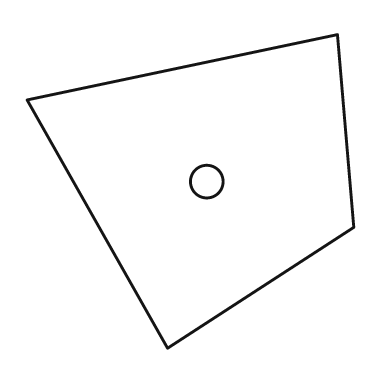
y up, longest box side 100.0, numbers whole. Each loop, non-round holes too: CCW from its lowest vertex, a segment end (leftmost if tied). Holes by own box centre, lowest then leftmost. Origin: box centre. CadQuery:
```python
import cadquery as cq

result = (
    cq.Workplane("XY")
    .moveTo(-7.0, -48.0)
    .lineTo(50.0, -11.0)
    .lineTo(45.0, 48.0)
    .lineTo(-50.0, 28.0)
    .close()
    .moveTo(5.0, 3.0)
    .circle(5.0)
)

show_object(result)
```